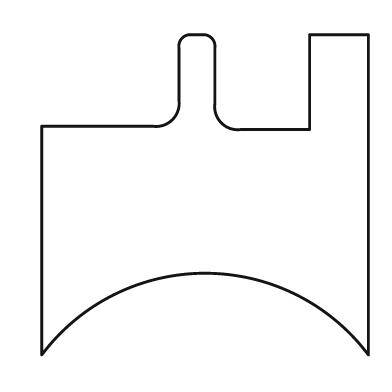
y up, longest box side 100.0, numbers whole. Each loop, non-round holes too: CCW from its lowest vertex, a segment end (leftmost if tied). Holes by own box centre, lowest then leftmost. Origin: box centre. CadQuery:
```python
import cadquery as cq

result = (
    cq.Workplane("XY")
    .moveTo(-50.0, -49.0)
    .threePointArc((0.0, -24.0), (50.0, -49.0))
    .lineTo(50.0, 49.0)
    .lineTo(32.0, 49.0)
    .lineTo(32.0, 20.0)
    .lineTo(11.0, 20.0)
    .threePointArc((5.0, 22.0), (3.0, 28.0))
    .lineTo(3.0, 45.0)
    .threePointArc((2.0, 48.0), (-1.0, 49.0))
    .lineTo(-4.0, 49.0)
    .threePointArc((-7.0, 48.0), (-8.0, 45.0))
    .lineTo(-8.0, 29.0)
    .threePointArc((-10.0, 23.0), (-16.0, 21.0))
    .lineTo(-50.0, 21.0)
    .close()
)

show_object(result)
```